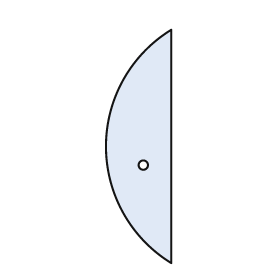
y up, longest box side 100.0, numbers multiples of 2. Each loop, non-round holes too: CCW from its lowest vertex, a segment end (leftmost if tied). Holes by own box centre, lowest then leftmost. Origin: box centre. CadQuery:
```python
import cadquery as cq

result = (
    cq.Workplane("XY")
    .moveTo(14.0, -50.0)
    .lineTo(14.0, 50.0)
    .threePointArc((-14.0, 0.0), (14.0, -50.0))
    .close()
    .moveTo(2.0, -8.0)
    .circle(2.0)
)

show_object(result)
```